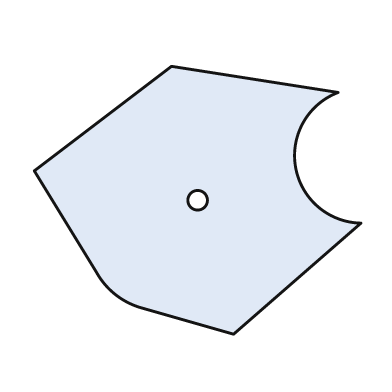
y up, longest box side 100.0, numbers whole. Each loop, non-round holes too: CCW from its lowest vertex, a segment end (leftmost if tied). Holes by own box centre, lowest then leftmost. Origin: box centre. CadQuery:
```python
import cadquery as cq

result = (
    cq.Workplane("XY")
    .moveTo(11.0, -41.0)
    .lineTo(50.0, -7.0)
    .threePointArc((30.0, 10.0), (43.0, 33.0))
    .lineTo(-8.0, 41.0)
    .lineTo(-50.0, 9.0)
    .lineTo(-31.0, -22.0)
    .threePointArc((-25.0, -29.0), (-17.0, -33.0))
    .close()
    .moveTo(0.0, 0.0)
    .circle(3.0)
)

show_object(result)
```